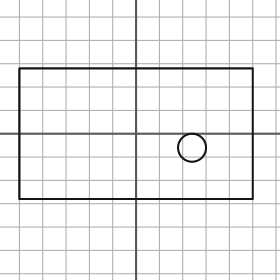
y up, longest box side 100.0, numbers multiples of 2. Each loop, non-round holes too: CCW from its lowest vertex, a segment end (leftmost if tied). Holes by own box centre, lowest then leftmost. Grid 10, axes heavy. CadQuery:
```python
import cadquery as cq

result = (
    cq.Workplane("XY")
    .moveTo(-50.0, -28.0)
    .lineTo(50.0, -28.0)
    .lineTo(50.0, 28.0)
    .lineTo(-50.0, 28.0)
    .close()
    .moveTo(24.0, -6.0)
    .circle(6.0)
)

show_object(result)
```